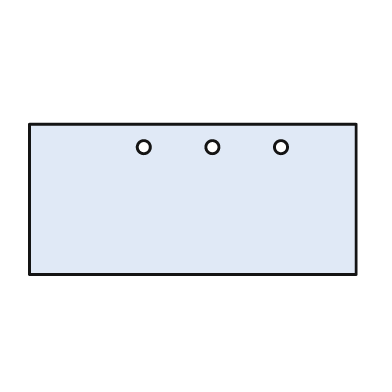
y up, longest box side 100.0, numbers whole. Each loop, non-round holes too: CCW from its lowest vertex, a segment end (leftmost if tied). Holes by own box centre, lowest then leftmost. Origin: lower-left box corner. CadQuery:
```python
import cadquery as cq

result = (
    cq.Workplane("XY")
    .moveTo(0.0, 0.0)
    .lineTo(100.0, 0.0)
    .lineTo(100.0, 46.0)
    .lineTo(0.0, 46.0)
    .close()
    .moveTo(35.0, 39.0)
    .circle(2.0)
    .moveTo(56.0, 39.0)
    .circle(2.0)
    .moveTo(77.0, 39.0)
    .circle(2.0)
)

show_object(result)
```